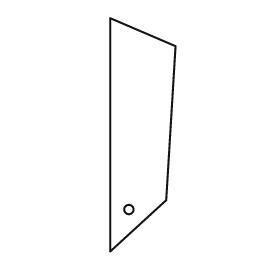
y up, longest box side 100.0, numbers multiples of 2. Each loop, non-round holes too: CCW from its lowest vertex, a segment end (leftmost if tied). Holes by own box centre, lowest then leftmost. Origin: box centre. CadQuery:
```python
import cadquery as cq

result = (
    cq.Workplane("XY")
    .moveTo(-14.0, -50.0)
    .lineTo(10.0, -28.0)
    .lineTo(14.0, 38.0)
    .lineTo(-14.0, 50.0)
    .close()
    .moveTo(-6.0, -32.0)
    .circle(2.0)
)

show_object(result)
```